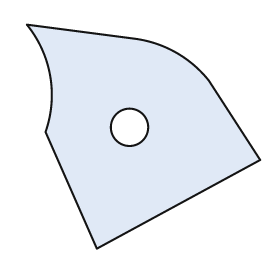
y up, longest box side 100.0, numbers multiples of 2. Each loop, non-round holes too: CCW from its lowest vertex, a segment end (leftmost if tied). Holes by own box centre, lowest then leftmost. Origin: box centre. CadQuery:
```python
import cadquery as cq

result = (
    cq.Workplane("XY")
    .moveTo(-20.0, -48.0)
    .lineTo(50.0, -10.0)
    .lineTo(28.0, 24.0)
    .threePointArc((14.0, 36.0), (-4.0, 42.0))
    .lineTo(-50.0, 48.0)
    .threePointArc((-40.0, 26.0), (-42.0, 2.0))
    .close()
    .moveTo(-6.0, 4.0)
    .circle(8.0)
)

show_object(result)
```